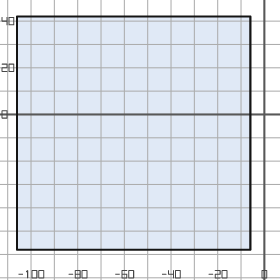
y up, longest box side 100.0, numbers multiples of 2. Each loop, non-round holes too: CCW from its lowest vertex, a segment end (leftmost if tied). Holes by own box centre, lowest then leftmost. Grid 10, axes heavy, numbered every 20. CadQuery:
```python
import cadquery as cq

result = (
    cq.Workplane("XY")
    .moveTo(-106.0, -58.0)
    .lineTo(-6.0, -58.0)
    .lineTo(-6.0, 42.0)
    .lineTo(-106.0, 42.0)
    .close()
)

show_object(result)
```